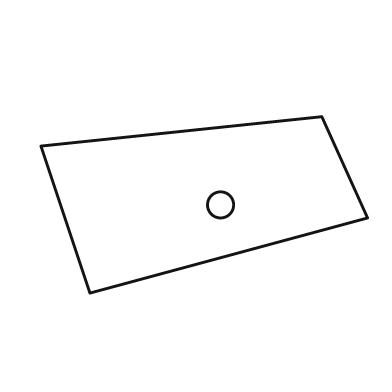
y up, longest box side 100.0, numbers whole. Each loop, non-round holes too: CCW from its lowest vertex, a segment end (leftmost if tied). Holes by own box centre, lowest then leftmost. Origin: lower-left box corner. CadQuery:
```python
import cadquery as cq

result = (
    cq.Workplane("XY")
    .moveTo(15.0, 0.0)
    .lineTo(100.0, 23.0)
    .lineTo(86.0, 54.0)
    .lineTo(0.0, 45.0)
    .close()
    .moveTo(55.0, 27.0)
    .circle(4.0)
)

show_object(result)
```